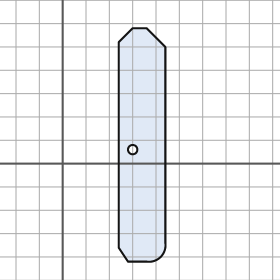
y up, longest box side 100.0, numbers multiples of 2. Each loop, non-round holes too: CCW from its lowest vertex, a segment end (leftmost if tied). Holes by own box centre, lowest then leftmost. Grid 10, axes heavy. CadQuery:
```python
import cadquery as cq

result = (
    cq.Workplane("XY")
    .moveTo(28.0, -42.0)
    .lineTo(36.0, -42.0)
    .threePointArc((42.0, -40.0), (44.0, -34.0))
    .lineTo(44.0, 50.0)
    .lineTo(36.0, 58.0)
    .lineTo(30.0, 58.0)
    .lineTo(24.0, 52.0)
    .lineTo(24.0, -36.0)
    .close()
    .moveTo(30.0, 6.0)
    .circle(2.0)
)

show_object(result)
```